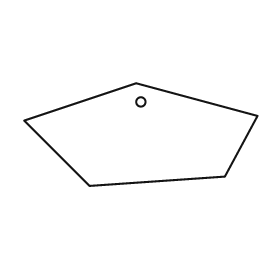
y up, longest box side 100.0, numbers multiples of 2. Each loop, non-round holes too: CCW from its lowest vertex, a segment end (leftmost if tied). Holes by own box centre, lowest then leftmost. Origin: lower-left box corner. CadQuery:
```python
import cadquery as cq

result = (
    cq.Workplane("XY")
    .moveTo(28.0, 0.0)
    .lineTo(86.0, 4.0)
    .lineTo(100.0, 30.0)
    .lineTo(48.0, 44.0)
    .lineTo(0.0, 28.0)
    .close()
    .moveTo(50.0, 36.0)
    .circle(2.0)
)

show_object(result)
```